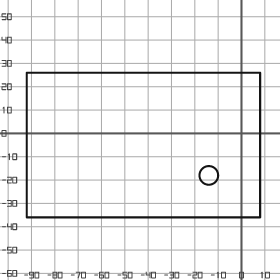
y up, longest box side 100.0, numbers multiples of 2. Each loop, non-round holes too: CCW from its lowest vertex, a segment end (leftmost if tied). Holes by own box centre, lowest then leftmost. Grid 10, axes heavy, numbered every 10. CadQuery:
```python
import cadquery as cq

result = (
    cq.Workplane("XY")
    .moveTo(-92.0, -36.0)
    .lineTo(8.0, -36.0)
    .lineTo(8.0, 26.0)
    .lineTo(-92.0, 26.0)
    .close()
    .moveTo(-14.0, -18.0)
    .circle(4.0)
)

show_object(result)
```